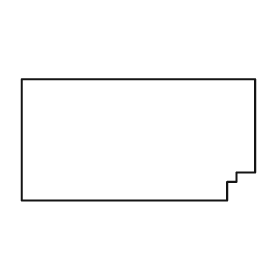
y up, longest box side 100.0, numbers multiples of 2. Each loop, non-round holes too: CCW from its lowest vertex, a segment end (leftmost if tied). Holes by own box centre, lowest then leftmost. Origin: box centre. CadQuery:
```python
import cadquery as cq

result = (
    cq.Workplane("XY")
    .moveTo(-50.0, -26.0)
    .lineTo(38.0, -26.0)
    .lineTo(38.0, -18.0)
    .lineTo(42.0, -18.0)
    .lineTo(42.0, -14.0)
    .lineTo(50.0, -14.0)
    .lineTo(50.0, 26.0)
    .lineTo(-50.0, 26.0)
    .close()
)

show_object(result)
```